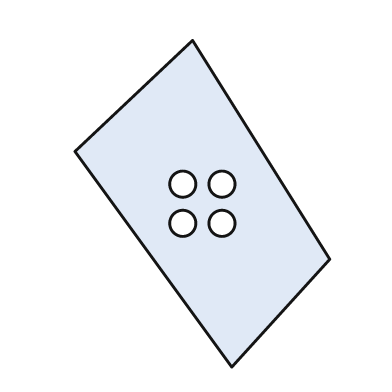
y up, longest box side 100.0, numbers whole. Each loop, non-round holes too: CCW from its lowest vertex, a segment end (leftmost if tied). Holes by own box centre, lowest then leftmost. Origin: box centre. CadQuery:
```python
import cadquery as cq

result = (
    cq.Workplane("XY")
    .moveTo(9.0, -50.0)
    .lineTo(39.0, -17.0)
    .lineTo(-3.0, 50.0)
    .lineTo(-39.0, 16.0)
    .close()
    .moveTo(-6.0, -6.0)
    .circle(4.0)
    .moveTo(6.0, -6.0)
    .circle(4.0)
    .moveTo(-6.0, 6.0)
    .circle(4.0)
    .moveTo(6.0, 6.0)
    .circle(4.0)
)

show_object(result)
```